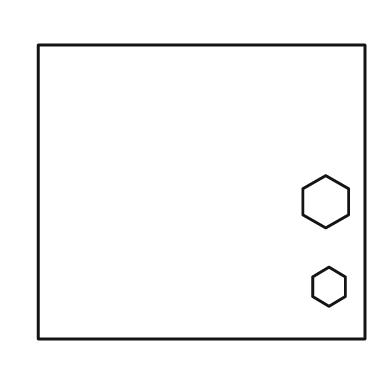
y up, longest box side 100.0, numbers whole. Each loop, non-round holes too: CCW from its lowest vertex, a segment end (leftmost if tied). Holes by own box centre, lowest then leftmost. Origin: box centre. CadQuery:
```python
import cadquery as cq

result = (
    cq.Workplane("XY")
    .moveTo(-50.0, -45.0)
    .lineTo(50.0, -45.0)
    .lineTo(50.0, 45.0)
    .lineTo(-50.0, 45.0)
    .close()
    .moveTo(39.0, -35.0)
    .lineTo(44.0, -32.0)
    .lineTo(44.0, -26.0)
    .lineTo(39.0, -23.0)
    .lineTo(34.0, -26.0)
    .lineTo(34.0, -32.0)
    .close()
    .moveTo(38.0, -11.0)
    .lineTo(45.0, -7.0)
    .lineTo(45.0, 1.0)
    .lineTo(38.0, 5.0)
    .lineTo(31.0, 1.0)
    .lineTo(31.0, -7.0)
    .close()
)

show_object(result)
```